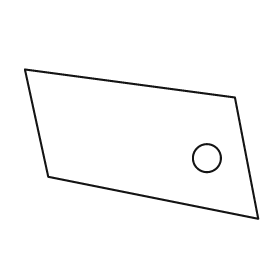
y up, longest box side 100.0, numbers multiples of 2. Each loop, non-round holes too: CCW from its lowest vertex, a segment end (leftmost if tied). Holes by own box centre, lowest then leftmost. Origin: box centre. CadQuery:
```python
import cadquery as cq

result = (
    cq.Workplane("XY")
    .moveTo(50.0, -32.0)
    .lineTo(40.0, 20.0)
    .lineTo(-50.0, 32.0)
    .lineTo(-40.0, -14.0)
    .close()
    .moveTo(28.0, -6.0)
    .circle(6.0)
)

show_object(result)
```